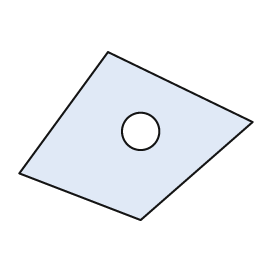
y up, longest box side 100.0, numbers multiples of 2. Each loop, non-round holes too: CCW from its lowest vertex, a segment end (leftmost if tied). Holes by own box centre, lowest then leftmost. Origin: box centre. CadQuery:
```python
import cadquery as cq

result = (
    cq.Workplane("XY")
    .moveTo(2.0, -36.0)
    .lineTo(50.0, 6.0)
    .lineTo(-12.0, 36.0)
    .lineTo(-50.0, -16.0)
    .close()
    .moveTo(2.0, 2.0)
    .circle(8.0)
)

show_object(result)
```